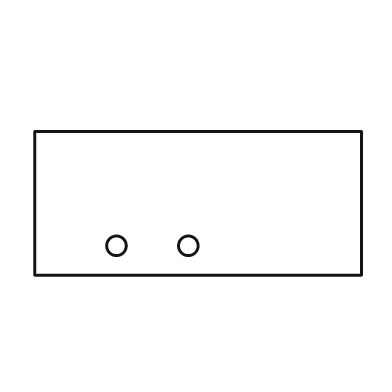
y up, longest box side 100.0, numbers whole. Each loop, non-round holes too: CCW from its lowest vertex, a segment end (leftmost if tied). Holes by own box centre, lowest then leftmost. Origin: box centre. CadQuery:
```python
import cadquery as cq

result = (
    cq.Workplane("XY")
    .moveTo(-50.0, -22.0)
    .lineTo(50.0, -22.0)
    .lineTo(50.0, 22.0)
    .lineTo(-50.0, 22.0)
    .close()
    .moveTo(-25.0, -13.0)
    .circle(3.0)
    .moveTo(-3.0, -13.0)
    .circle(3.0)
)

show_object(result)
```